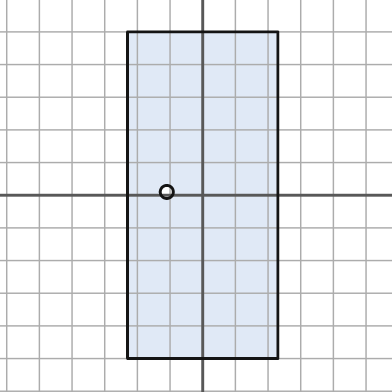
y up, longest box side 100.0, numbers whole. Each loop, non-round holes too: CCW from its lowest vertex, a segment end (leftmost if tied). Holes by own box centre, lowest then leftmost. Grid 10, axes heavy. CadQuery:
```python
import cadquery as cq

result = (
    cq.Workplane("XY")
    .moveTo(-23.0, -50.0)
    .lineTo(23.0, -50.0)
    .lineTo(23.0, 50.0)
    .lineTo(-23.0, 50.0)
    .close()
    .moveTo(-11.0, 1.0)
    .circle(2.0)
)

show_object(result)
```